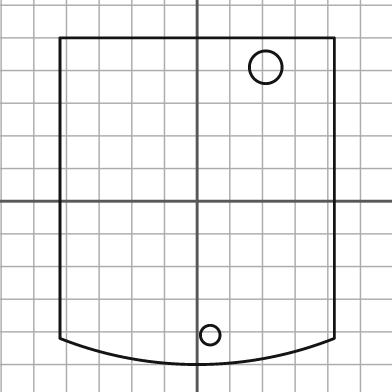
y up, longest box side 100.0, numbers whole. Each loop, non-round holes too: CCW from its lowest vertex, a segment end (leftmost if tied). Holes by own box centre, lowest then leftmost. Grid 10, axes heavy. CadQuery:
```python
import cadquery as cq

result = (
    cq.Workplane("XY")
    .moveTo(-42.0, -42.0)
    .threePointArc((0.0, -50.0), (42.0, -42.0))
    .lineTo(42.0, 50.0)
    .lineTo(-42.0, 50.0)
    .close()
    .moveTo(4.0, -41.0)
    .circle(3.0)
    .moveTo(21.0, 41.0)
    .circle(5.0)
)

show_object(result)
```